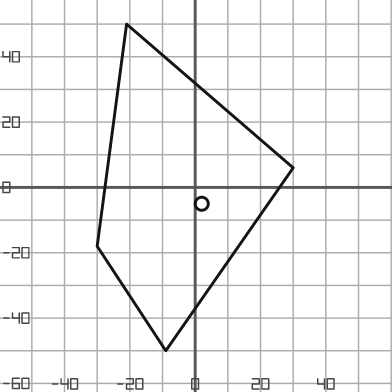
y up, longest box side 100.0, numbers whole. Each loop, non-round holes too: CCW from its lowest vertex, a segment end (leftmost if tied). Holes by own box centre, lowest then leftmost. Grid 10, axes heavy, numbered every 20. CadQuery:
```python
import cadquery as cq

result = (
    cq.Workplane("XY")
    .moveTo(-9.0, -50.0)
    .lineTo(30.0, 6.0)
    .lineTo(-21.0, 50.0)
    .lineTo(-30.0, -18.0)
    .close()
    .moveTo(2.0, -5.0)
    .circle(2.0)
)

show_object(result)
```